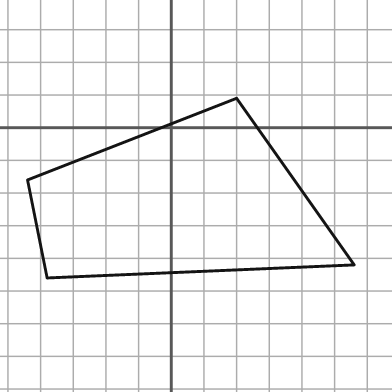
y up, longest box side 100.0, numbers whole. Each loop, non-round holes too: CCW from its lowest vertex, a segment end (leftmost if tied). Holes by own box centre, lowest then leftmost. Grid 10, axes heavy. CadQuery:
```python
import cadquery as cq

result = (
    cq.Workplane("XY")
    .moveTo(-38.0, -46.0)
    .lineTo(56.0, -42.0)
    .lineTo(20.0, 9.0)
    .lineTo(-44.0, -16.0)
    .close()
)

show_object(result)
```